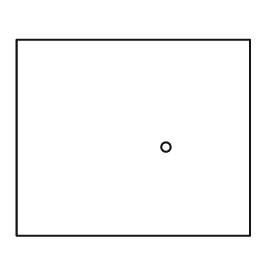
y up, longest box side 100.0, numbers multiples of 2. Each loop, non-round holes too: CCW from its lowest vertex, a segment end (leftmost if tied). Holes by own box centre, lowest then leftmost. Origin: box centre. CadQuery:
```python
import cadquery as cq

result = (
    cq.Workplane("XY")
    .moveTo(-50.0, -42.0)
    .lineTo(50.0, -42.0)
    .lineTo(50.0, 42.0)
    .lineTo(-50.0, 42.0)
    .close()
    .moveTo(14.0, -4.0)
    .circle(2.0)
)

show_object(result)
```